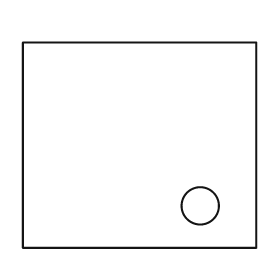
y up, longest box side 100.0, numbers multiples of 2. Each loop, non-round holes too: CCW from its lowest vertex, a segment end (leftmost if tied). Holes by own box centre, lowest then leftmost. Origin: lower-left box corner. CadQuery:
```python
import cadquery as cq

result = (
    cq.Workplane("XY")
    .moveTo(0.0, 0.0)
    .lineTo(100.0, 0.0)
    .lineTo(100.0, 88.0)
    .lineTo(0.0, 88.0)
    .close()
    .moveTo(76.0, 18.0)
    .circle(8.0)
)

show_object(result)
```